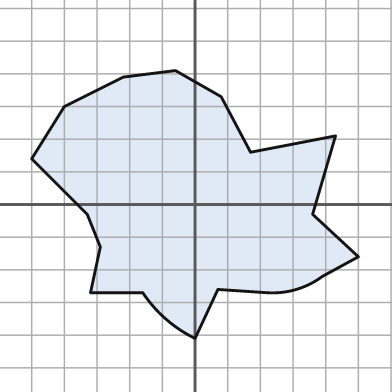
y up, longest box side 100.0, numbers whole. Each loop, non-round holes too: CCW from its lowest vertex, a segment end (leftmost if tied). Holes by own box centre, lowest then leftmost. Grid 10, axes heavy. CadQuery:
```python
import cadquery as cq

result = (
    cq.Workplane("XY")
    .moveTo(0.0, -41.0)
    .lineTo(7.0, -26.0)
    .lineTo(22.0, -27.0)
    .threePointArc((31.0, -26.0), (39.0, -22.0))
    .lineTo(50.0, -16.0)
    .lineTo(36.0, -3.0)
    .lineTo(43.0, 21.0)
    .lineTo(17.0, 16.0)
    .lineTo(8.0, 33.0)
    .lineTo(-6.0, 41.0)
    .lineTo(-22.0, 39.0)
    .lineTo(-40.0, 30.0)
    .lineTo(-50.0, 14.0)
    .lineTo(-33.0, -3.0)
    .lineTo(-29.0, -13.0)
    .lineTo(-32.0, -27.0)
    .lineTo(-16.0, -27.0)
    .threePointArc((-9.0, -35.0), (0.0, -41.0))
    .close()
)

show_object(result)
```